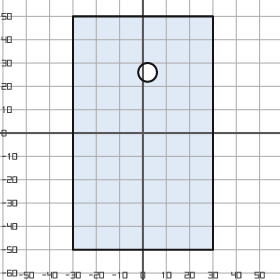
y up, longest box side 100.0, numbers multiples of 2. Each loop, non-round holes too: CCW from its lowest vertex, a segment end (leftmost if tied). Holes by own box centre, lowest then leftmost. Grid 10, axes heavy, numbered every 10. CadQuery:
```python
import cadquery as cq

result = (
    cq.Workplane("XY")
    .moveTo(-30.0, -50.0)
    .lineTo(30.0, -50.0)
    .lineTo(30.0, 50.0)
    .lineTo(-30.0, 50.0)
    .close()
    .moveTo(2.0, 26.0)
    .circle(4.0)
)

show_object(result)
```